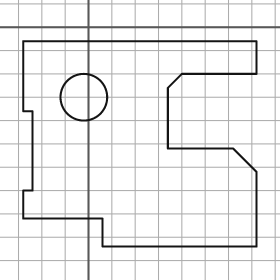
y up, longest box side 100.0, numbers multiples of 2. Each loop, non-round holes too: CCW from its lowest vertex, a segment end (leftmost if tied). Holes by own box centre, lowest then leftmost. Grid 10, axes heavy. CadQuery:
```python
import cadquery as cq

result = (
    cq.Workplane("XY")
    .moveTo(6.0, -94.0)
    .lineTo(72.0, -94.0)
    .lineTo(72.0, -62.0)
    .lineTo(62.0, -52.0)
    .lineTo(34.0, -52.0)
    .lineTo(34.0, -26.0)
    .lineTo(40.0, -20.0)
    .lineTo(72.0, -20.0)
    .lineTo(72.0, -6.0)
    .lineTo(-28.0, -6.0)
    .lineTo(-28.0, -36.0)
    .lineTo(-24.0, -36.0)
    .lineTo(-24.0, -70.0)
    .lineTo(-28.0, -70.0)
    .lineTo(-28.0, -82.0)
    .lineTo(6.0, -82.0)
    .close()
    .moveTo(-2.0, -30.0)
    .circle(10.0)
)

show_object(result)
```